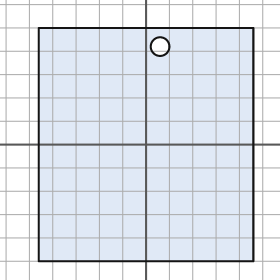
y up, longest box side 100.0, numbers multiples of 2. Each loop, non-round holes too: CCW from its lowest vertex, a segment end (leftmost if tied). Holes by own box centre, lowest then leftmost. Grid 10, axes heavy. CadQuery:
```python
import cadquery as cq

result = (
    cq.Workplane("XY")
    .moveTo(-46.0, -50.0)
    .lineTo(46.0, -50.0)
    .lineTo(46.0, 50.0)
    .lineTo(-46.0, 50.0)
    .close()
    .moveTo(6.0, 42.0)
    .circle(4.0)
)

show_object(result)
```